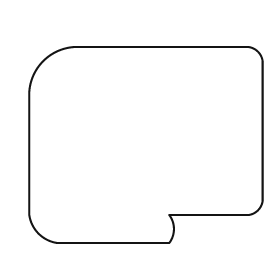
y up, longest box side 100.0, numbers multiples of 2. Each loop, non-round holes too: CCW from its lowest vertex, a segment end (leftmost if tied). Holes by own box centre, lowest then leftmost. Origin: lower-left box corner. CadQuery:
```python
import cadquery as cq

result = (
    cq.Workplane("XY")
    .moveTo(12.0, 0.0)
    .lineTo(60.0, 0.0)
    .threePointArc((62.0, 6.0), (60.0, 12.0))
    .lineTo(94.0, 12.0)
    .threePointArc((98.0, 14.0), (100.0, 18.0))
    .lineTo(100.0, 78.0)
    .threePointArc((98.0, 82.0), (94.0, 84.0))
    .lineTo(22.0, 84.0)
    .threePointArc((6.0, 78.0), (0.0, 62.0))
    .lineTo(0.0, 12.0)
    .threePointArc((4.0, 4.0), (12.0, 0.0))
    .close()
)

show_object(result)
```